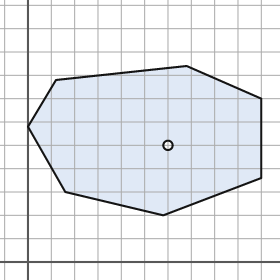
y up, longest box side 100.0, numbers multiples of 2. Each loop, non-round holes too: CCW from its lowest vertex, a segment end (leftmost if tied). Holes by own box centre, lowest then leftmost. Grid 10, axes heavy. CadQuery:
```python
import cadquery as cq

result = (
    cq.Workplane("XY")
    .moveTo(58.0, 20.0)
    .lineTo(100.0, 36.0)
    .lineTo(100.0, 70.0)
    .lineTo(68.0, 84.0)
    .lineTo(12.0, 78.0)
    .lineTo(0.0, 58.0)
    .lineTo(16.0, 30.0)
    .close()
    .moveTo(60.0, 50.0)
    .circle(2.0)
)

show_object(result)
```